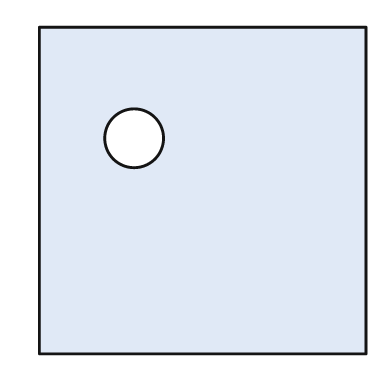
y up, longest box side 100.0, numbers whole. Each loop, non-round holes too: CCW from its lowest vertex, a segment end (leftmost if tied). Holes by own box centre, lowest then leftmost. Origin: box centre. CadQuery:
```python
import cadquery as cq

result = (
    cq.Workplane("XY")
    .moveTo(-50.0, -50.0)
    .lineTo(50.0, -50.0)
    .lineTo(50.0, 50.0)
    .lineTo(-50.0, 50.0)
    .close()
    .moveTo(-21.0, 16.0)
    .circle(9.0)
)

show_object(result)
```